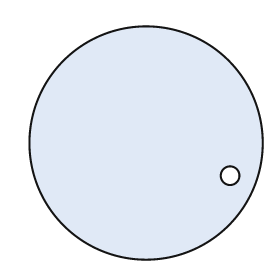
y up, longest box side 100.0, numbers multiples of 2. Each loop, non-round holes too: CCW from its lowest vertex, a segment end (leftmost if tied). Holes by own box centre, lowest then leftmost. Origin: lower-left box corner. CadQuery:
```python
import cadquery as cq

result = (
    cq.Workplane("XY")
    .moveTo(50.0, 50.0)
    .circle(50.0)
    .moveTo(86.0, 36.0)
    .circle(4.0)
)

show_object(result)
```